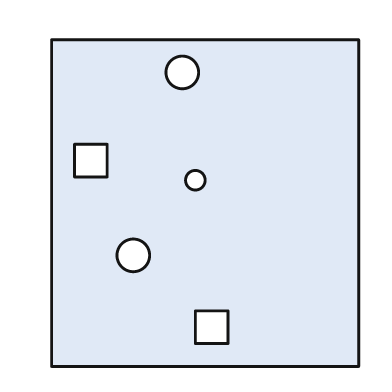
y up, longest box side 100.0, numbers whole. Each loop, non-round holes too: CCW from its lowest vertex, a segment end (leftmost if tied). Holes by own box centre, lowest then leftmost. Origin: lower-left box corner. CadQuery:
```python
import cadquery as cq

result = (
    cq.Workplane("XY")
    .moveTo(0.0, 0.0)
    .lineTo(94.0, 0.0)
    .lineTo(94.0, 100.0)
    .lineTo(0.0, 100.0)
    .close()
    .moveTo(44.0, 7.0)
    .lineTo(54.0, 7.0)
    .lineTo(54.0, 17.0)
    .lineTo(44.0, 17.0)
    .close()
    .moveTo(25.0, 34.0)
    .circle(5.0)
    .moveTo(44.0, 57.0)
    .circle(3.0)
    .moveTo(7.0, 58.0)
    .lineTo(17.0, 58.0)
    .lineTo(17.0, 68.0)
    .lineTo(7.0, 68.0)
    .close()
    .moveTo(40.0, 90.0)
    .circle(5.0)
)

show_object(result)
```